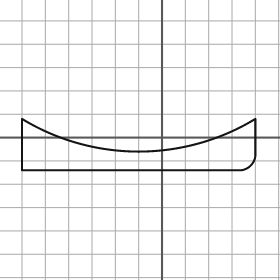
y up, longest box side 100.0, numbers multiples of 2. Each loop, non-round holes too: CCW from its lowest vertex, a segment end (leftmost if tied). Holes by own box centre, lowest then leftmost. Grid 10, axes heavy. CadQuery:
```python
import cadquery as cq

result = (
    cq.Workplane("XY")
    .moveTo(-60.0, -14.0)
    .lineTo(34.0, -14.0)
    .threePointArc((38.0, -12.0), (40.0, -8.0))
    .lineTo(40.0, 8.0)
    .threePointArc((-10.0, -6.0), (-60.0, 8.0))
    .close()
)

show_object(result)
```